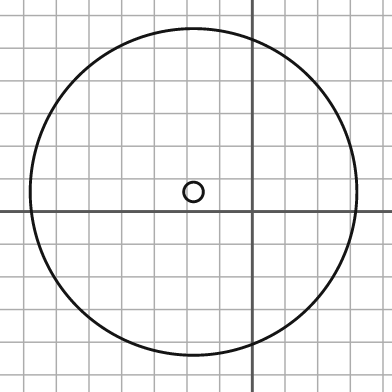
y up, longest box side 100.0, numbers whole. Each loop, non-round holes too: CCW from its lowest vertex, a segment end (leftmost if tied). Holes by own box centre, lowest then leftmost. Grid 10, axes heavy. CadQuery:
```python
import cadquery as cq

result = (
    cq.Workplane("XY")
    .moveTo(-18.0, 6.0)
    .circle(50.0)
    .moveTo(-18.0, 6.0)
    .circle(3.0)
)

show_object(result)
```